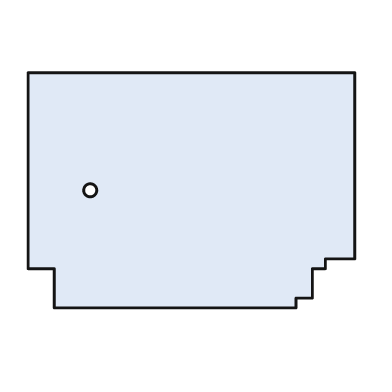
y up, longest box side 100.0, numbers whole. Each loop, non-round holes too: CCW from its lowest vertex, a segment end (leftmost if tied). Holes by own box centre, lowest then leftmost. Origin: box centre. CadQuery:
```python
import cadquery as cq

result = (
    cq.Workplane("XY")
    .moveTo(-42.0, -36.0)
    .lineTo(32.0, -36.0)
    .lineTo(32.0, -33.0)
    .lineTo(37.0, -33.0)
    .lineTo(37.0, -24.0)
    .lineTo(41.0, -24.0)
    .lineTo(41.0, -21.0)
    .lineTo(50.0, -21.0)
    .lineTo(50.0, 36.0)
    .lineTo(-50.0, 36.0)
    .lineTo(-50.0, -24.0)
    .lineTo(-42.0, -24.0)
    .close()
    .moveTo(-31.0, 0.0)
    .circle(2.0)
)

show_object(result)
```